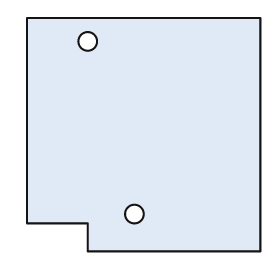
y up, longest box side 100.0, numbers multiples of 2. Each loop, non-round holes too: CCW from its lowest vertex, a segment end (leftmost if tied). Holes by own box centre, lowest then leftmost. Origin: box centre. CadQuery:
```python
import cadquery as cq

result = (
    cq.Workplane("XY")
    .moveTo(-24.0, -50.0)
    .lineTo(50.0, -50.0)
    .lineTo(50.0, 50.0)
    .lineTo(-50.0, 50.0)
    .lineTo(-50.0, -38.0)
    .lineTo(-24.0, -38.0)
    .close()
    .moveTo(-4.0, -34.0)
    .circle(4.0)
    .moveTo(-24.0, 40.0)
    .circle(4.0)
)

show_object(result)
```